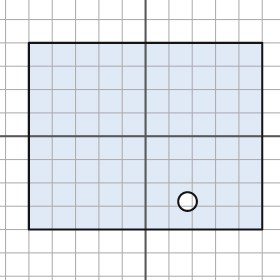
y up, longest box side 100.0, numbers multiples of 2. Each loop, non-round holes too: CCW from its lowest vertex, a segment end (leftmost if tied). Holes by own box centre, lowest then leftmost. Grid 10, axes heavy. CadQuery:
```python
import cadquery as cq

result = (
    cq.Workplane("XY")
    .moveTo(-50.0, -40.0)
    .lineTo(50.0, -40.0)
    .lineTo(50.0, 40.0)
    .lineTo(-50.0, 40.0)
    .close()
    .moveTo(18.0, -28.0)
    .circle(4.0)
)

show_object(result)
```